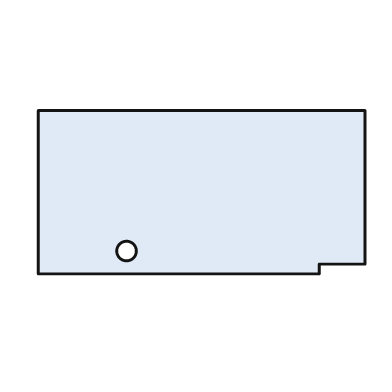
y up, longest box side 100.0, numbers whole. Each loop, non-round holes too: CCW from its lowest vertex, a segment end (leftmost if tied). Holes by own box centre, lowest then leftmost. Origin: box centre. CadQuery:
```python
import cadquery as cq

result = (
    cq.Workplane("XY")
    .moveTo(-50.0, -25.0)
    .lineTo(36.0, -25.0)
    .lineTo(36.0, -22.0)
    .lineTo(50.0, -22.0)
    .lineTo(50.0, 25.0)
    .lineTo(-50.0, 25.0)
    .close()
    .moveTo(-23.0, -18.0)
    .circle(3.0)
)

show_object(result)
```